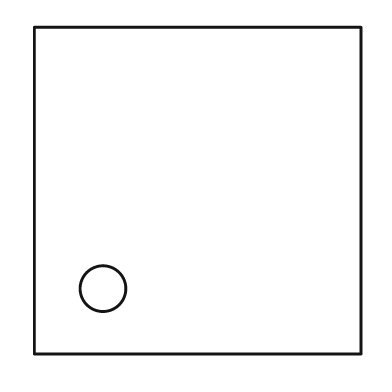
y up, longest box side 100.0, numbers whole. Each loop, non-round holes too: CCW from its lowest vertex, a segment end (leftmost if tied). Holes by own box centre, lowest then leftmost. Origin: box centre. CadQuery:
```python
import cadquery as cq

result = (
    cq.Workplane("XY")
    .moveTo(-50.0, -50.0)
    .lineTo(50.0, -50.0)
    .lineTo(50.0, 50.0)
    .lineTo(-50.0, 50.0)
    .close()
    .moveTo(-29.0, -30.0)
    .circle(7.0)
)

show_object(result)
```